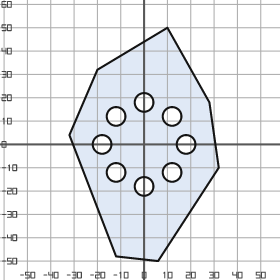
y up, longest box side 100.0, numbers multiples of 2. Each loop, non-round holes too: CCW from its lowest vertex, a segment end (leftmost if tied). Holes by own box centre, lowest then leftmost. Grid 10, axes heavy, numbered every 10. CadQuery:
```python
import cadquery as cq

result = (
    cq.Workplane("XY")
    .moveTo(6.0, -50.0)
    .lineTo(32.0, -10.0)
    .lineTo(28.0, 18.0)
    .lineTo(10.0, 50.0)
    .lineTo(-20.0, 32.0)
    .lineTo(-32.0, 4.0)
    .lineTo(-12.0, -48.0)
    .close()
    .moveTo(0.0, -18.0)
    .circle(4.0)
    .moveTo(-12.0, -12.0)
    .circle(4.0)
    .moveTo(12.0, -12.0)
    .circle(4.0)
    .moveTo(-18.0, 0.0)
    .circle(4.0)
    .moveTo(18.0, 0.0)
    .circle(4.0)
    .moveTo(-12.0, 12.0)
    .circle(4.0)
    .moveTo(12.0, 12.0)
    .circle(4.0)
    .moveTo(0.0, 18.0)
    .circle(4.0)
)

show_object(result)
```